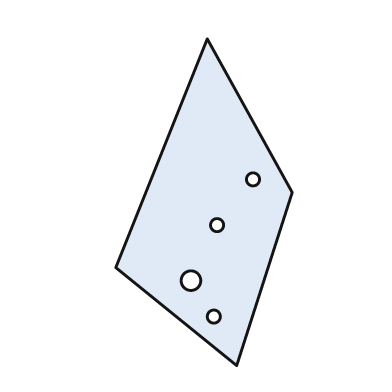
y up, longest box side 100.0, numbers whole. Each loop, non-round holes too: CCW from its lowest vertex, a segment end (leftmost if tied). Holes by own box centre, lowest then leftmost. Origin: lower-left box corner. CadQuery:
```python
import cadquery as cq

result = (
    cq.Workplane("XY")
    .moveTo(37.0, 0.0)
    .lineTo(54.0, 53.0)
    .lineTo(28.0, 100.0)
    .lineTo(0.0, 30.0)
    .close()
    .moveTo(30.0, 15.0)
    .circle(2.0)
    .moveTo(23.0, 26.0)
    .circle(3.0)
    .moveTo(31.0, 43.0)
    .circle(2.0)
    .moveTo(42.0, 57.0)
    .circle(2.0)
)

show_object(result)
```